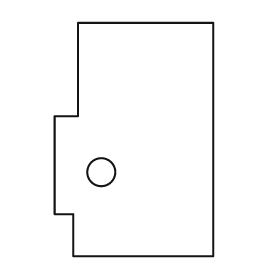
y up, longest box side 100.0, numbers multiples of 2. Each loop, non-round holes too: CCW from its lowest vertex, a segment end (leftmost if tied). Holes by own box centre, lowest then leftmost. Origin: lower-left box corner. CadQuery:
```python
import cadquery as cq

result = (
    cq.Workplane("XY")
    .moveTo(8.0, 0.0)
    .lineTo(68.0, 0.0)
    .lineTo(68.0, 100.0)
    .lineTo(10.0, 100.0)
    .lineTo(10.0, 60.0)
    .lineTo(0.0, 60.0)
    .lineTo(0.0, 18.0)
    .lineTo(8.0, 18.0)
    .close()
    .moveTo(20.0, 36.0)
    .circle(6.0)
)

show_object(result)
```